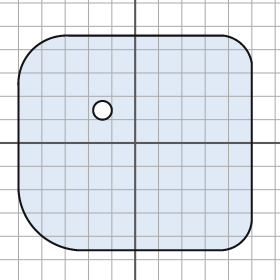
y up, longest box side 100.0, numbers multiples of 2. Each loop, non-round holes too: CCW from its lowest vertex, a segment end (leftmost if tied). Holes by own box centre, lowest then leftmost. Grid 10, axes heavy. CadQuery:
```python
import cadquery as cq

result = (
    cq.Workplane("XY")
    .moveTo(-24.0, -46.0)
    .lineTo(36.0, -46.0)
    .threePointArc((46.0, -42.0), (50.0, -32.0))
    .lineTo(50.0, 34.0)
    .threePointArc((46.0, 42.0), (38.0, 46.0))
    .lineTo(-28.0, 46.0)
    .threePointArc((-44.0, 40.0), (-50.0, 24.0))
    .lineTo(-50.0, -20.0)
    .threePointArc((-42.0, -38.0), (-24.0, -46.0))
    .close()
    .moveTo(-14.0, 14.0)
    .circle(4.0)
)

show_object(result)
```